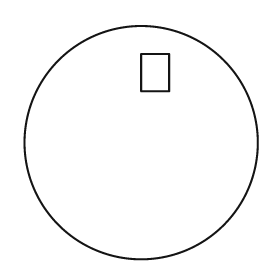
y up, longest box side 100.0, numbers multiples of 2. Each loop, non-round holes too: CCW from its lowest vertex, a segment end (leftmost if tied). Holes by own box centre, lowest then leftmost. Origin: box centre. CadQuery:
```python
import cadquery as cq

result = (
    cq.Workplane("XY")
    .moveTo(0.0, 0.0)
    .circle(50.0)
    .moveTo(0.0, 22.0)
    .lineTo(12.0, 22.0)
    .lineTo(12.0, 38.0)
    .lineTo(0.0, 38.0)
    .close()
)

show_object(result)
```